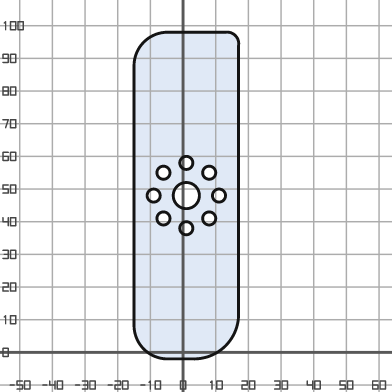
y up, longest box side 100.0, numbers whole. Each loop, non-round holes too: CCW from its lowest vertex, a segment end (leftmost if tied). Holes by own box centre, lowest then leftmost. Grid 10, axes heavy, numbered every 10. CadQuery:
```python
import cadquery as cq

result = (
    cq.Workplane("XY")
    .moveTo(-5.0, -2.0)
    .lineTo(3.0, -2.0)
    .threePointArc((13.0, 2.0), (17.0, 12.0))
    .lineTo(17.0, 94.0)
    .threePointArc((16.0, 97.0), (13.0, 98.0))
    .lineTo(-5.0, 98.0)
    .threePointArc((-12.0, 95.0), (-15.0, 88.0))
    .lineTo(-15.0, 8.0)
    .threePointArc((-12.0, 1.0), (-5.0, -2.0))
    .close()
    .moveTo(1.0, 38.0)
    .circle(2.0)
    .moveTo(-6.0, 41.0)
    .circle(2.0)
    .moveTo(8.0, 41.0)
    .circle(2.0)
    .moveTo(-9.0, 48.0)
    .circle(2.0)
    .moveTo(1.0, 48.0)
    .circle(4.0)
    .moveTo(11.0, 48.0)
    .circle(2.0)
    .moveTo(-6.0, 55.0)
    .circle(2.0)
    .moveTo(8.0, 55.0)
    .circle(2.0)
    .moveTo(1.0, 58.0)
    .circle(2.0)
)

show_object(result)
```